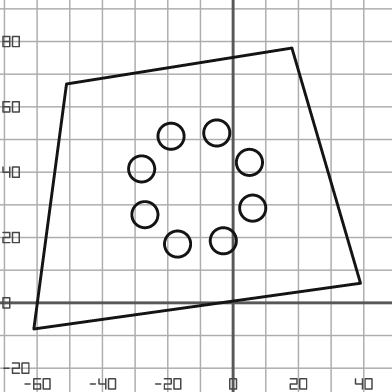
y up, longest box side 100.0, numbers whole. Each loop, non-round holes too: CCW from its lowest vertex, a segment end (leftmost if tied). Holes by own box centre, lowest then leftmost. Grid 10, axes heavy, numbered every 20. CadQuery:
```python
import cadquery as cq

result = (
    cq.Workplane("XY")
    .moveTo(-61.0, -8.0)
    .lineTo(39.0, 6.0)
    .lineTo(18.0, 78.0)
    .lineTo(-51.0, 67.0)
    .close()
    .moveTo(-17.0, 18.0)
    .circle(4.0)
    .moveTo(-3.0, 19.0)
    .circle(4.0)
    .moveTo(-27.0, 27.0)
    .circle(4.0)
    .moveTo(6.0, 29.0)
    .circle(4.0)
    .moveTo(-28.0, 41.0)
    .circle(4.0)
    .moveTo(5.0, 43.0)
    .circle(4.0)
    .moveTo(-19.0, 51.0)
    .circle(4.0)
    .moveTo(-5.0, 52.0)
    .circle(4.0)
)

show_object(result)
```